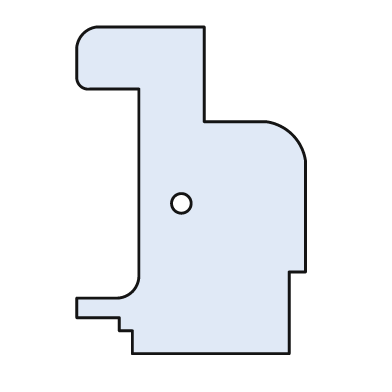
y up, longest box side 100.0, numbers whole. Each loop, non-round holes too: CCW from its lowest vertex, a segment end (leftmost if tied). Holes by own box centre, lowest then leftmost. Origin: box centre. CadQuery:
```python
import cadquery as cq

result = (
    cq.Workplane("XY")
    .moveTo(-18.0, -50.0)
    .lineTo(30.0, -50.0)
    .lineTo(30.0, -25.0)
    .lineTo(35.0, -25.0)
    .lineTo(35.0, 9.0)
    .threePointArc((31.0, 17.0), (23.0, 21.0))
    .lineTo(4.0, 21.0)
    .lineTo(4.0, 50.0)
    .lineTo(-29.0, 50.0)
    .threePointArc((-33.0, 48.0), (-35.0, 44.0))
    .lineTo(-35.0, 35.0)
    .threePointArc((-34.0, 32.0), (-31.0, 31.0))
    .lineTo(-16.0, 31.0)
    .lineTo(-16.0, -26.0)
    .threePointArc((-18.0, -31.0), (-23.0, -33.0))
    .lineTo(-35.0, -33.0)
    .lineTo(-35.0, -39.0)
    .lineTo(-22.0, -39.0)
    .lineTo(-22.0, -43.0)
    .lineTo(-18.0, -43.0)
    .close()
    .moveTo(-3.0, -4.0)
    .circle(3.0)
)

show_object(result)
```